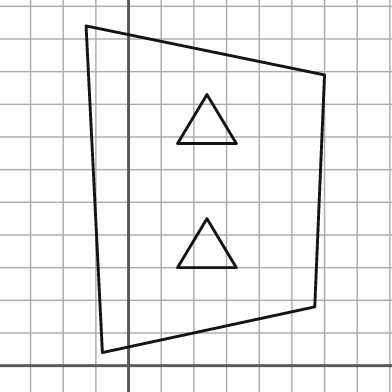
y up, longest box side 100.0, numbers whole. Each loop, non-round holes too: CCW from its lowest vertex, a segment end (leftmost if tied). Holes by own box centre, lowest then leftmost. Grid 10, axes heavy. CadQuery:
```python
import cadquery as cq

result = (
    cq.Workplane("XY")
    .moveTo(-8.0, 4.0)
    .lineTo(57.0, 18.0)
    .lineTo(60.0, 89.0)
    .lineTo(-13.0, 104.0)
    .close()
    .moveTo(15.0, 30.0)
    .lineTo(33.0, 30.0)
    .lineTo(24.0, 45.0)
    .close()
    .moveTo(15.0, 68.0)
    .lineTo(33.0, 68.0)
    .lineTo(24.0, 83.0)
    .close()
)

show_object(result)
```